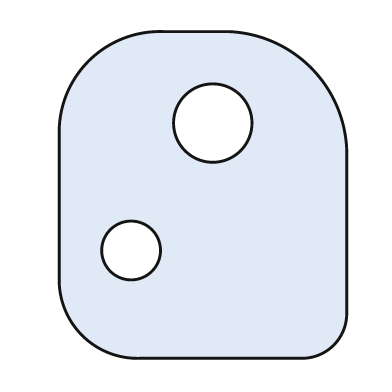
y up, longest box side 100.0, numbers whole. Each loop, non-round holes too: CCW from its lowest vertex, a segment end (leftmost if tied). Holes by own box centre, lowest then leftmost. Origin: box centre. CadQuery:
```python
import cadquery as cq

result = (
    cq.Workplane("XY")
    .moveTo(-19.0, -50.0)
    .lineTo(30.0, -50.0)
    .threePointArc((40.0, -46.0), (44.0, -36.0))
    .lineTo(44.0, 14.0)
    .threePointArc((33.0, 39.0), (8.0, 50.0))
    .lineTo(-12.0, 50.0)
    .threePointArc((-35.0, 41.0), (-44.0, 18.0))
    .lineTo(-44.0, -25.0)
    .threePointArc((-37.0, -43.0), (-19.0, -50.0))
    .close()
    .moveTo(-22.0, -17.0)
    .circle(9.0)
    .moveTo(3.0, 22.0)
    .circle(12.0)
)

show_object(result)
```